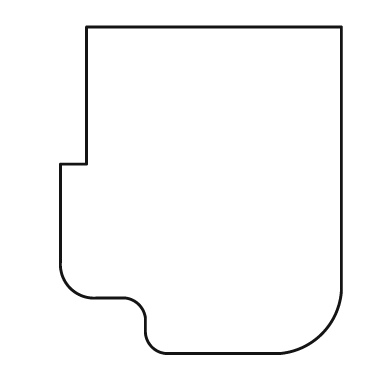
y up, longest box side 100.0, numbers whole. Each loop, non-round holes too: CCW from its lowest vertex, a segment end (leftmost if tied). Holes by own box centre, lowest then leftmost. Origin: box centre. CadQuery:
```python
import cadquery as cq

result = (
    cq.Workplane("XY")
    .moveTo(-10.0, -50.0)
    .lineTo(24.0, -50.0)
    .threePointArc((37.0, -44.0), (43.0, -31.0))
    .lineTo(43.0, 50.0)
    .lineTo(-35.0, 50.0)
    .lineTo(-35.0, 8.0)
    .lineTo(-43.0, 8.0)
    .lineTo(-43.0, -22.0)
    .threePointArc((-40.0, -30.0), (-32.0, -33.0))
    .lineTo(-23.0, -33.0)
    .threePointArc((-19.0, -35.0), (-17.0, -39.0))
    .lineTo(-17.0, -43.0)
    .threePointArc((-15.0, -48.0), (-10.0, -50.0))
    .close()
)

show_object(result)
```